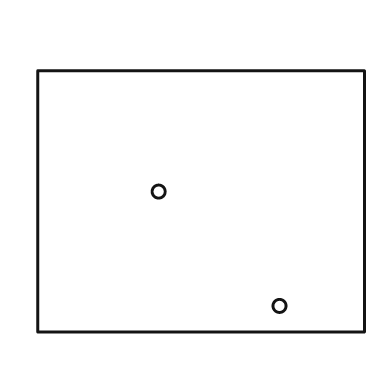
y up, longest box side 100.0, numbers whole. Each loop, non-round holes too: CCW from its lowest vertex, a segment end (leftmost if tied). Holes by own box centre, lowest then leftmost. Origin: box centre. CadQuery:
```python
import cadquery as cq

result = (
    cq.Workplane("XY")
    .moveTo(-50.0, -40.0)
    .lineTo(50.0, -40.0)
    .lineTo(50.0, 40.0)
    .lineTo(-50.0, 40.0)
    .close()
    .moveTo(24.0, -32.0)
    .circle(2.0)
    .moveTo(-13.0, 3.0)
    .circle(2.0)
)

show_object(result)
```